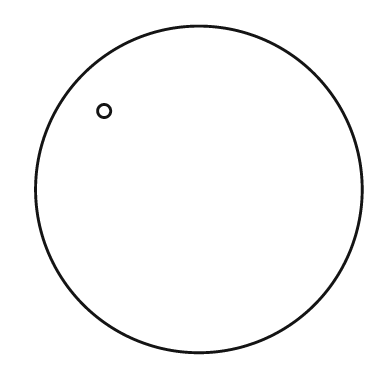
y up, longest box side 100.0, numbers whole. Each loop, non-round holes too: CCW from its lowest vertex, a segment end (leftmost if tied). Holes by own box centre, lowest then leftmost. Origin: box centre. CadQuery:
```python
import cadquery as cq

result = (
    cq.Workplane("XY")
    .moveTo(0.0, 0.0)
    .circle(50.0)
    .moveTo(-29.0, 24.0)
    .circle(2.0)
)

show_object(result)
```